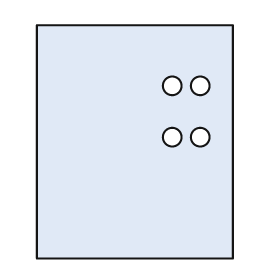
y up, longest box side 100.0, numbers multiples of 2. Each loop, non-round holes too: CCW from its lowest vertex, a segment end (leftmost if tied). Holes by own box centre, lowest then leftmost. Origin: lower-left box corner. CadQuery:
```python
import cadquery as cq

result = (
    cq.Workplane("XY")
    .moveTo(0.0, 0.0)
    .lineTo(84.0, 0.0)
    .lineTo(84.0, 100.0)
    .lineTo(0.0, 100.0)
    .close()
    .moveTo(58.0, 52.0)
    .circle(4.0)
    .moveTo(70.0, 52.0)
    .circle(4.0)
    .moveTo(58.0, 74.0)
    .circle(4.0)
    .moveTo(70.0, 74.0)
    .circle(4.0)
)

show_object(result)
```